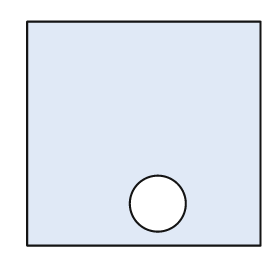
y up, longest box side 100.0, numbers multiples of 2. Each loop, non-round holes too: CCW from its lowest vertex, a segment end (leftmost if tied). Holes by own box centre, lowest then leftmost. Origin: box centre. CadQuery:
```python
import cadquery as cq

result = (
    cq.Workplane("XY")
    .moveTo(-50.0, -48.0)
    .lineTo(50.0, -48.0)
    .lineTo(50.0, 48.0)
    .lineTo(-50.0, 48.0)
    .close()
    .moveTo(6.0, -30.0)
    .circle(12.0)
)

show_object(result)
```